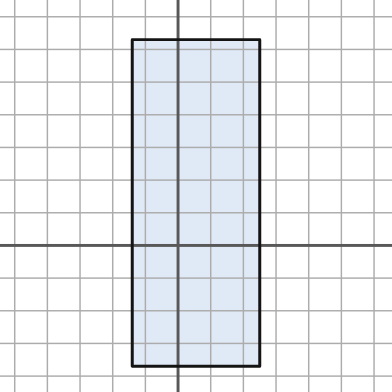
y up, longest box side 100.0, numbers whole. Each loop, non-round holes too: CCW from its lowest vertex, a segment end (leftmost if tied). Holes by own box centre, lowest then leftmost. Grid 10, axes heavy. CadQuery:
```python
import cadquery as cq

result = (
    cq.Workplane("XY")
    .moveTo(-14.0, -37.0)
    .lineTo(25.0, -37.0)
    .lineTo(25.0, 63.0)
    .lineTo(-14.0, 63.0)
    .close()
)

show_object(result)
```